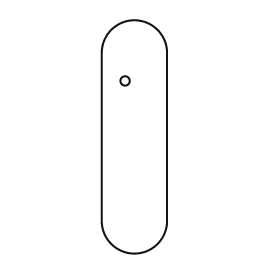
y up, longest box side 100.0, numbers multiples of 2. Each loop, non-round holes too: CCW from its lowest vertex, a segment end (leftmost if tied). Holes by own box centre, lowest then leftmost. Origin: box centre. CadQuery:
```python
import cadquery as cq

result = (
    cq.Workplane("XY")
    .moveTo(-14.0, -36.0)
    .threePointArc((0.0, -50.0), (14.0, -36.0))
    .lineTo(14.0, 36.0)
    .threePointArc((0.0, 50.0), (-14.0, 36.0))
    .close()
    .moveTo(-4.0, 24.0)
    .circle(2.0)
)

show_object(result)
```